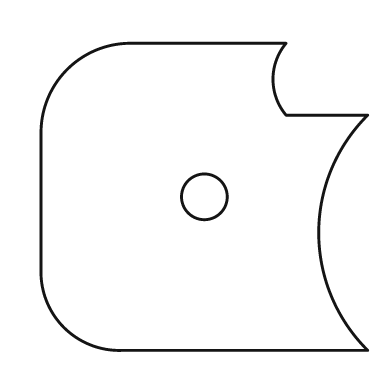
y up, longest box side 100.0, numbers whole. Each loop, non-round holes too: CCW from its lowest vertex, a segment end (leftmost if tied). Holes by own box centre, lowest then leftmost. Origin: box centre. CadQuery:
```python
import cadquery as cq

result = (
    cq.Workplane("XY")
    .moveTo(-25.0, -47.0)
    .lineTo(50.0, -47.0)
    .threePointArc((35.0, -11.0), (50.0, 25.0))
    .lineTo(25.0, 25.0)
    .threePointArc((21.0, 36.0), (25.0, 47.0))
    .lineTo(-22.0, 47.0)
    .threePointArc((-42.0, 39.0), (-50.0, 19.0))
    .lineTo(-50.0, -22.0)
    .threePointArc((-43.0, -40.0), (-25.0, -47.0))
    .close()
    .moveTo(0.0, 0.0)
    .circle(7.0)
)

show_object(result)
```